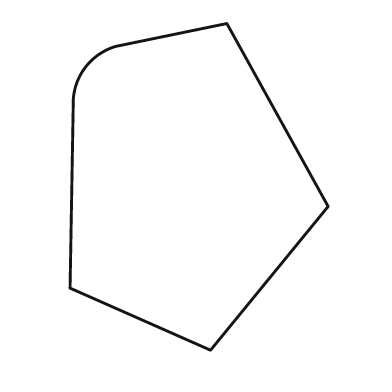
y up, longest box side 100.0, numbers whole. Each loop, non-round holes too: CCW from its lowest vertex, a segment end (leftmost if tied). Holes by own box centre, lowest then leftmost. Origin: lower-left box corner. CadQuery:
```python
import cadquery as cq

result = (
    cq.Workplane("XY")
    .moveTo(43.0, 0.0)
    .lineTo(79.0, 44.0)
    .lineTo(48.0, 100.0)
    .lineTo(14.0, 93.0)
    .threePointArc((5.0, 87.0), (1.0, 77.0))
    .lineTo(0.0, 19.0)
    .close()
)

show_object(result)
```